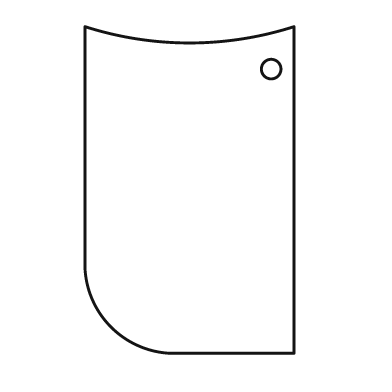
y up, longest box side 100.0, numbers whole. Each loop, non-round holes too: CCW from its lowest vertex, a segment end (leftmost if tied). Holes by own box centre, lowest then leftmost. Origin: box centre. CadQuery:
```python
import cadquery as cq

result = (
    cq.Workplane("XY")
    .moveTo(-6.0, -50.0)
    .lineTo(32.0, -50.0)
    .lineTo(32.0, 50.0)
    .threePointArc((0.0, 45.0), (-32.0, 50.0))
    .lineTo(-32.0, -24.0)
    .threePointArc((-24.0, -42.0), (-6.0, -50.0))
    .close()
    .moveTo(25.0, 37.0)
    .circle(3.0)
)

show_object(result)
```